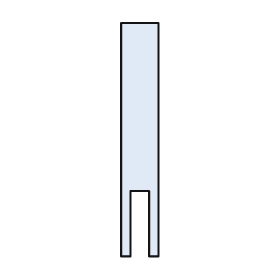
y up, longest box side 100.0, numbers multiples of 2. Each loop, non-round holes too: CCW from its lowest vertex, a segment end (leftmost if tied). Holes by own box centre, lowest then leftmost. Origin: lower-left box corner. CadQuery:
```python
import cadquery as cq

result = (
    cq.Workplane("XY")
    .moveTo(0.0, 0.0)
    .lineTo(4.0, 0.0)
    .lineTo(4.0, 28.0)
    .lineTo(12.0, 28.0)
    .lineTo(12.0, 0.0)
    .lineTo(16.0, 0.0)
    .lineTo(16.0, 100.0)
    .lineTo(0.0, 100.0)
    .close()
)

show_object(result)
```